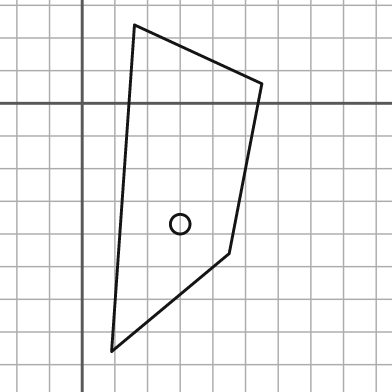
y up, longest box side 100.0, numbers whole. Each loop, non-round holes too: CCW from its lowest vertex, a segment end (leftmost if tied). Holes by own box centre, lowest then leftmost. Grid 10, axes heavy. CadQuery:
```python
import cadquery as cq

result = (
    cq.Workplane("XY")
    .moveTo(9.0, -76.0)
    .lineTo(45.0, -46.0)
    .lineTo(55.0, 6.0)
    .lineTo(16.0, 24.0)
    .close()
    .moveTo(30.0, -37.0)
    .circle(3.0)
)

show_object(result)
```